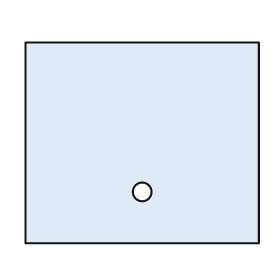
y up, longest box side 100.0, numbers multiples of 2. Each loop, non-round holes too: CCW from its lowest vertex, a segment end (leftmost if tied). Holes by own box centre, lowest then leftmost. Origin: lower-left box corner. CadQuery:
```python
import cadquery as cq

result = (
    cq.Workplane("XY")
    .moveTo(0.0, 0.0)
    .lineTo(100.0, 0.0)
    .lineTo(100.0, 86.0)
    .lineTo(0.0, 86.0)
    .close()
    .moveTo(50.0, 22.0)
    .circle(4.0)
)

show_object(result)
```